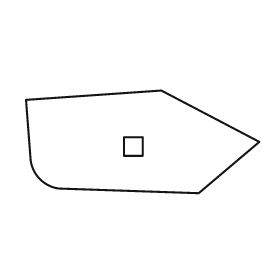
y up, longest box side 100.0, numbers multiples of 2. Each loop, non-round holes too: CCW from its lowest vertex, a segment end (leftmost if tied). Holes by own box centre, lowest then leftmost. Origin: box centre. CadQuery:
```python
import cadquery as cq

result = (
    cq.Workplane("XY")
    .moveTo(24.0, -22.0)
    .lineTo(50.0, 0.0)
    .lineTo(8.0, 22.0)
    .lineTo(-50.0, 18.0)
    .lineTo(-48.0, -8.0)
    .threePointArc((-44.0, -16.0), (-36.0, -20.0))
    .close()
    .moveTo(-8.0, -6.0)
    .lineTo(0.0, -6.0)
    .lineTo(0.0, 2.0)
    .lineTo(-8.0, 2.0)
    .close()
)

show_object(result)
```